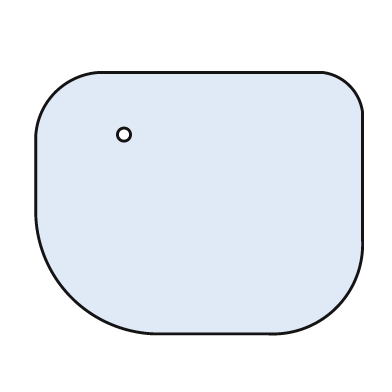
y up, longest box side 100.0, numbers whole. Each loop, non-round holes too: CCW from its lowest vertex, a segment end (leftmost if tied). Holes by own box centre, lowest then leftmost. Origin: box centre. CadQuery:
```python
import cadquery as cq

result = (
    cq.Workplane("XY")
    .moveTo(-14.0, -40.0)
    .lineTo(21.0, -40.0)
    .threePointArc((42.0, -32.0), (50.0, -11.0))
    .lineTo(50.0, 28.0)
    .threePointArc((46.0, 36.0), (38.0, 40.0))
    .lineTo(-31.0, 40.0)
    .threePointArc((-44.0, 34.0), (-50.0, 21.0))
    .lineTo(-50.0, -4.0)
    .threePointArc((-39.0, -29.0), (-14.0, -40.0))
    .close()
    .moveTo(-23.0, 21.0)
    .circle(2.0)
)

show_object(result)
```